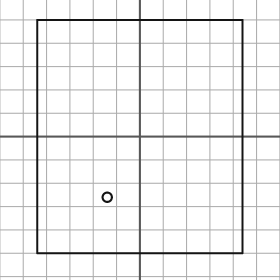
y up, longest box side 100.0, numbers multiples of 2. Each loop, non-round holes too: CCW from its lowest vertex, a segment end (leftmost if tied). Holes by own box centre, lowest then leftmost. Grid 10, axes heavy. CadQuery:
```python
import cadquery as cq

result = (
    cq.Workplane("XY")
    .moveTo(-44.0, -50.0)
    .lineTo(44.0, -50.0)
    .lineTo(44.0, 50.0)
    .lineTo(-44.0, 50.0)
    .close()
    .moveTo(-14.0, -26.0)
    .circle(2.0)
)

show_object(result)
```